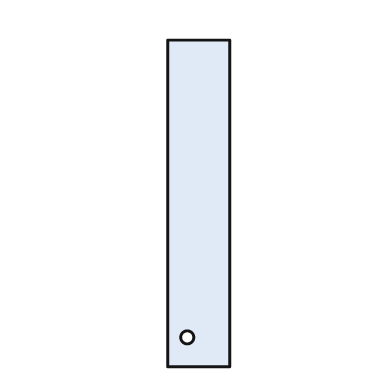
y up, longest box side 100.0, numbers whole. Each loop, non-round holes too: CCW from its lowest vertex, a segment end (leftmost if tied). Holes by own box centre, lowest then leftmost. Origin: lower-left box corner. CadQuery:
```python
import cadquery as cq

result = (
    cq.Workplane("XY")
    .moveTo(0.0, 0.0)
    .lineTo(19.0, 0.0)
    .lineTo(19.0, 100.0)
    .lineTo(0.0, 100.0)
    .close()
    .moveTo(6.0, 9.0)
    .circle(2.0)
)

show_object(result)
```